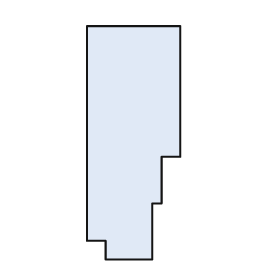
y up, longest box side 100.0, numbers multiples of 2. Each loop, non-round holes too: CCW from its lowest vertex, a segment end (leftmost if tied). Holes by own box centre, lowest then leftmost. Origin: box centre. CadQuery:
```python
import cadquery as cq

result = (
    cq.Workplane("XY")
    .moveTo(-12.0, -50.0)
    .lineTo(8.0, -50.0)
    .lineTo(8.0, -26.0)
    .lineTo(12.0, -26.0)
    .lineTo(12.0, -6.0)
    .lineTo(20.0, -6.0)
    .lineTo(20.0, 50.0)
    .lineTo(-20.0, 50.0)
    .lineTo(-20.0, -42.0)
    .lineTo(-12.0, -42.0)
    .close()
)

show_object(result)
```